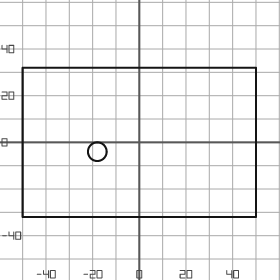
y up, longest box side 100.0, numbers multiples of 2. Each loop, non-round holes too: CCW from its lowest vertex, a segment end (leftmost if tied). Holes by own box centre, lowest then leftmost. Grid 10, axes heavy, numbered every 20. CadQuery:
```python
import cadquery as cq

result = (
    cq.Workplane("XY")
    .moveTo(-50.0, -32.0)
    .lineTo(50.0, -32.0)
    .lineTo(50.0, 32.0)
    .lineTo(-50.0, 32.0)
    .close()
    .moveTo(-18.0, -4.0)
    .circle(4.0)
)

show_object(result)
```